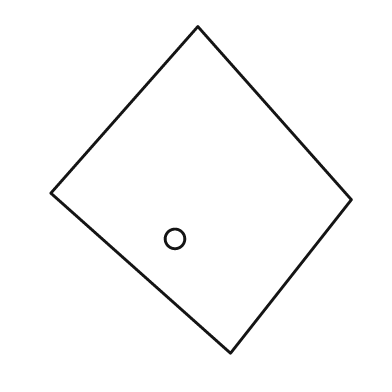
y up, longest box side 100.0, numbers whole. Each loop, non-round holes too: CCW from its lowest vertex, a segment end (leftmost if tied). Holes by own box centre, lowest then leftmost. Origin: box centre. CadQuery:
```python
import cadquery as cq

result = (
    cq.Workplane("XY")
    .moveTo(9.0, -50.0)
    .lineTo(46.0, -3.0)
    .lineTo(-1.0, 50.0)
    .lineTo(-46.0, -1.0)
    .close()
    .moveTo(-8.0, -15.0)
    .circle(3.0)
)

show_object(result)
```